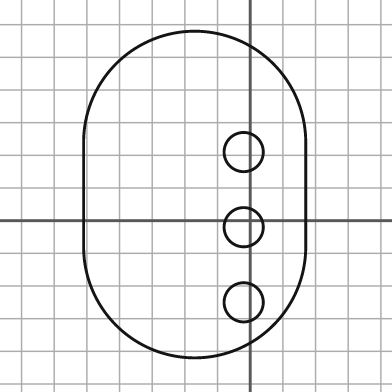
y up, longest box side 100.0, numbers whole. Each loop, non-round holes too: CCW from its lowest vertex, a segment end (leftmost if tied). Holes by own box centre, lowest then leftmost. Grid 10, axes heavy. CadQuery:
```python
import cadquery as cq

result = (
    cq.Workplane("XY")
    .moveTo(-51.0, -8.0)
    .threePointArc((-17.0, -42.0), (17.0, -8.0))
    .lineTo(17.0, 24.0)
    .threePointArc((-17.0, 58.0), (-51.0, 24.0))
    .close()
    .moveTo(-2.0, -25.0)
    .circle(6.0)
    .moveTo(-2.0, -2.0)
    .circle(6.0)
    .moveTo(-2.0, 21.0)
    .circle(6.0)
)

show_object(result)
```